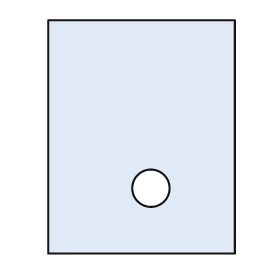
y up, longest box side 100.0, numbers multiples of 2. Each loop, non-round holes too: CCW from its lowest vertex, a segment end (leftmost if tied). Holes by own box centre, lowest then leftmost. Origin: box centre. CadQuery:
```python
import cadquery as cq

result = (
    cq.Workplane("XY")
    .moveTo(-40.0, -50.0)
    .lineTo(40.0, -50.0)
    .lineTo(40.0, 50.0)
    .lineTo(-40.0, 50.0)
    .close()
    .moveTo(4.0, -22.0)
    .circle(8.0)
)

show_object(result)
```